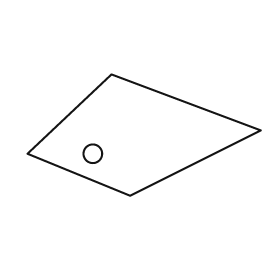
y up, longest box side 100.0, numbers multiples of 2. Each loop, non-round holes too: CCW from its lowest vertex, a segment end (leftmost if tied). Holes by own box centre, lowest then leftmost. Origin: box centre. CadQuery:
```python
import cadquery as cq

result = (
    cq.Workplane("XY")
    .moveTo(-6.0, -26.0)
    .lineTo(50.0, 2.0)
    .lineTo(-14.0, 26.0)
    .lineTo(-50.0, -8.0)
    .close()
    .moveTo(-22.0, -8.0)
    .circle(4.0)
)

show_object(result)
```